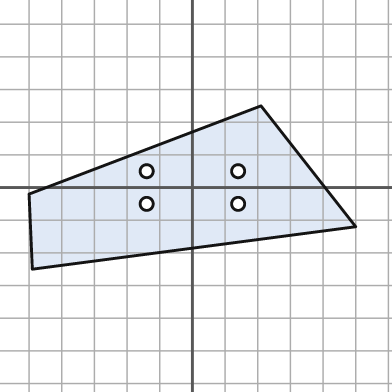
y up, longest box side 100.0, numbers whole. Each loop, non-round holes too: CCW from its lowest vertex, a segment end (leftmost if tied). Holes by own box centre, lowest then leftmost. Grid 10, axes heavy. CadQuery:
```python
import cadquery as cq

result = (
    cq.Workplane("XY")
    .moveTo(-49.0, -25.0)
    .lineTo(50.0, -12.0)
    .lineTo(21.0, 25.0)
    .lineTo(-50.0, -2.0)
    .close()
    .moveTo(-14.0, -5.0)
    .circle(2.0)
    .moveTo(14.0, -5.0)
    .circle(2.0)
    .moveTo(-14.0, 5.0)
    .circle(2.0)
    .moveTo(14.0, 5.0)
    .circle(2.0)
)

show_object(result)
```